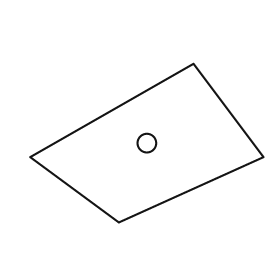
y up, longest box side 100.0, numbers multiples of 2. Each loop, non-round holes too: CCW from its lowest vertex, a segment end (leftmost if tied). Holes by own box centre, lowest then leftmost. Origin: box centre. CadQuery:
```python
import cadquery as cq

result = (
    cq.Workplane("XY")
    .moveTo(-12.0, -34.0)
    .lineTo(50.0, -6.0)
    .lineTo(20.0, 34.0)
    .lineTo(-50.0, -6.0)
    .close()
    .moveTo(0.0, 0.0)
    .circle(4.0)
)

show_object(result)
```